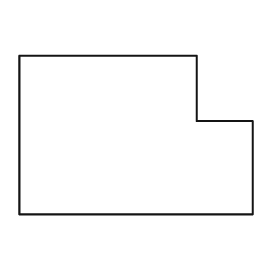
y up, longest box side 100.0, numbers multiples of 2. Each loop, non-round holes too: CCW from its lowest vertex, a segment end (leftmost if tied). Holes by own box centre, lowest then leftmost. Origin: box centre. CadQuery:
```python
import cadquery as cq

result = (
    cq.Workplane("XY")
    .moveTo(-50.0, -34.0)
    .lineTo(50.0, -34.0)
    .lineTo(50.0, 6.0)
    .lineTo(26.0, 6.0)
    .lineTo(26.0, 34.0)
    .lineTo(-50.0, 34.0)
    .close()
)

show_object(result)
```